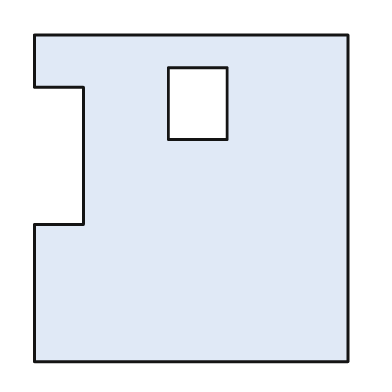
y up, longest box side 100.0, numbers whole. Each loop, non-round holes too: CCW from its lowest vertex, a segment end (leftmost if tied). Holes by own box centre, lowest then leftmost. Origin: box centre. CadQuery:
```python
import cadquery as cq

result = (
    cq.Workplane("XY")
    .moveTo(-48.0, -50.0)
    .lineTo(48.0, -50.0)
    .lineTo(48.0, 50.0)
    .lineTo(-48.0, 50.0)
    .lineTo(-48.0, 34.0)
    .lineTo(-33.0, 34.0)
    .lineTo(-33.0, -8.0)
    .lineTo(-48.0, -8.0)
    .close()
    .moveTo(-7.0, 18.0)
    .lineTo(11.0, 18.0)
    .lineTo(11.0, 40.0)
    .lineTo(-7.0, 40.0)
    .close()
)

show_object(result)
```